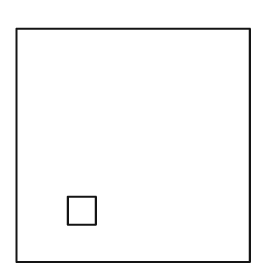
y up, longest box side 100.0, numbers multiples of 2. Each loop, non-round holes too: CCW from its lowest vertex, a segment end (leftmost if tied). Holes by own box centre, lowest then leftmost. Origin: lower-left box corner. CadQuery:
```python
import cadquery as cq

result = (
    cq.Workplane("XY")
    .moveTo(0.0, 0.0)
    .lineTo(100.0, 0.0)
    .lineTo(100.0, 100.0)
    .lineTo(0.0, 100.0)
    .close()
    .moveTo(22.0, 16.0)
    .lineTo(34.0, 16.0)
    .lineTo(34.0, 28.0)
    .lineTo(22.0, 28.0)
    .close()
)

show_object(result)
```